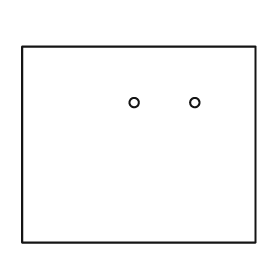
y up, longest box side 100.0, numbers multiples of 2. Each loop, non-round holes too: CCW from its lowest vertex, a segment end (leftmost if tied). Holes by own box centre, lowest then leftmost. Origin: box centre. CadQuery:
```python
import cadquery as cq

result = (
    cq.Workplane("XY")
    .moveTo(-50.0, -42.0)
    .lineTo(50.0, -42.0)
    .lineTo(50.0, 42.0)
    .lineTo(-50.0, 42.0)
    .close()
    .moveTo(-2.0, 18.0)
    .circle(2.0)
    .moveTo(24.0, 18.0)
    .circle(2.0)
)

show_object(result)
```